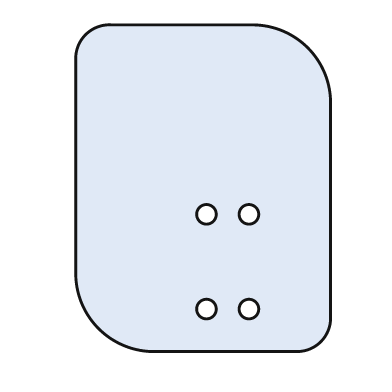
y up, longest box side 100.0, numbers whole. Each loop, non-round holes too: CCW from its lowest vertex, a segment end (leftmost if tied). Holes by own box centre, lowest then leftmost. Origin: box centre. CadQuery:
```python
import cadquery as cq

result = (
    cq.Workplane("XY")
    .moveTo(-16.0, -50.0)
    .lineTo(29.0, -50.0)
    .threePointArc((36.0, -47.0), (39.0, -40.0))
    .lineTo(39.0, 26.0)
    .threePointArc((32.0, 43.0), (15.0, 50.0))
    .lineTo(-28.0, 50.0)
    .threePointArc((-36.0, 47.0), (-39.0, 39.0))
    .lineTo(-39.0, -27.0)
    .threePointArc((-32.0, -43.0), (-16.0, -50.0))
    .close()
    .moveTo(1.0, -37.0)
    .circle(3.0)
    .moveTo(14.0, -37.0)
    .circle(3.0)
    .moveTo(1.0, -8.0)
    .circle(3.0)
    .moveTo(14.0, -8.0)
    .circle(3.0)
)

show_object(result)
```